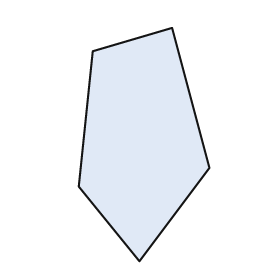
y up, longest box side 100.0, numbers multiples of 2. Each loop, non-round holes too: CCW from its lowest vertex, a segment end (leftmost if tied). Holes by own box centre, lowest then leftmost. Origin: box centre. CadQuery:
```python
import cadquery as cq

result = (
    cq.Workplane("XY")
    .moveTo(-2.0, -50.0)
    .lineTo(28.0, -10.0)
    .lineTo(12.0, 50.0)
    .lineTo(-22.0, 40.0)
    .lineTo(-28.0, -18.0)
    .close()
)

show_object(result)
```